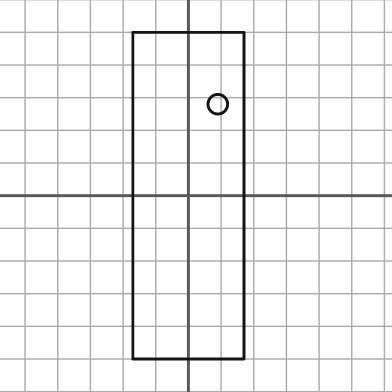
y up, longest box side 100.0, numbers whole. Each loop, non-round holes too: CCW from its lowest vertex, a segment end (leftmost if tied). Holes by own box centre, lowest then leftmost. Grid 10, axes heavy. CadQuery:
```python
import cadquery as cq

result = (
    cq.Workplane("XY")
    .moveTo(-17.0, -50.0)
    .lineTo(17.0, -50.0)
    .lineTo(17.0, 50.0)
    .lineTo(-17.0, 50.0)
    .close()
    .moveTo(9.0, 28.0)
    .circle(3.0)
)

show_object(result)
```